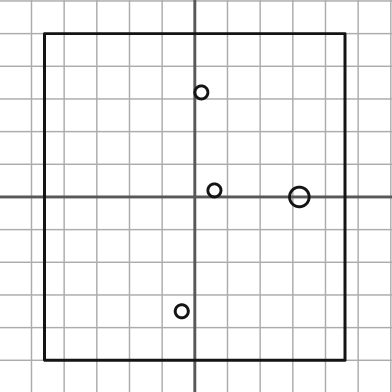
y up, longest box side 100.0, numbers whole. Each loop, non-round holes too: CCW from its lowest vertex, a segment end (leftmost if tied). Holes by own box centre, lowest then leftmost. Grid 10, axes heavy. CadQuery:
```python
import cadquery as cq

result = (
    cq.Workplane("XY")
    .moveTo(-46.0, -50.0)
    .lineTo(46.0, -50.0)
    .lineTo(46.0, 50.0)
    .lineTo(-46.0, 50.0)
    .close()
    .moveTo(-4.0, -35.0)
    .circle(2.0)
    .moveTo(32.0, 0.0)
    .circle(3.0)
    .moveTo(6.0, 2.0)
    .circle(2.0)
    .moveTo(2.0, 32.0)
    .circle(2.0)
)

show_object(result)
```